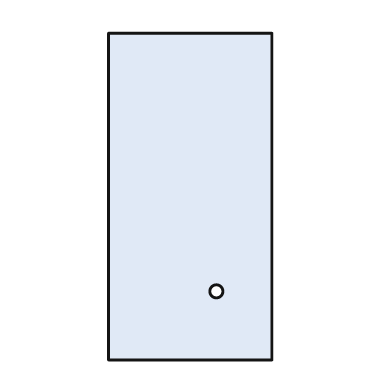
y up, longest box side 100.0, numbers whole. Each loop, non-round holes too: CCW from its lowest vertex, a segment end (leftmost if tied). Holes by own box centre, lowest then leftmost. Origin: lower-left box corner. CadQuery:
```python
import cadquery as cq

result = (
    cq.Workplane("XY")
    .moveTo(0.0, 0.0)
    .lineTo(50.0, 0.0)
    .lineTo(50.0, 100.0)
    .lineTo(0.0, 100.0)
    .close()
    .moveTo(33.0, 21.0)
    .circle(2.0)
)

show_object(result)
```